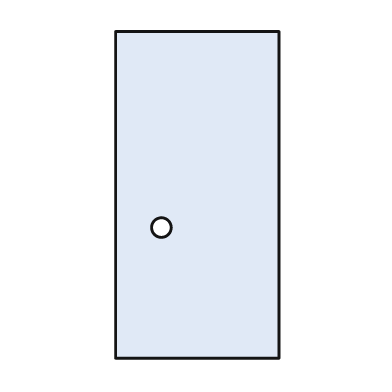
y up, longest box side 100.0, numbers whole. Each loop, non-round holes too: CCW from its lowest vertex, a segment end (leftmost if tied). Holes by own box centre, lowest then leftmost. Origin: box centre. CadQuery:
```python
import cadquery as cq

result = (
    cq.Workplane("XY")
    .moveTo(-25.0, -50.0)
    .lineTo(25.0, -50.0)
    .lineTo(25.0, 50.0)
    .lineTo(-25.0, 50.0)
    .close()
    .moveTo(-11.0, -10.0)
    .circle(3.0)
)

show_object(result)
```